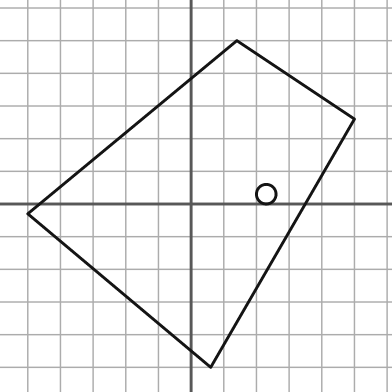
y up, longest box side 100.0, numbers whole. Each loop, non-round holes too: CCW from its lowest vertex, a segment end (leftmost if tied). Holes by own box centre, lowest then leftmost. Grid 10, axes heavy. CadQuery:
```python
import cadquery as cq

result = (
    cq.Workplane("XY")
    .moveTo(6.0, -50.0)
    .lineTo(50.0, 26.0)
    .lineTo(14.0, 50.0)
    .lineTo(-50.0, -3.0)
    .close()
    .moveTo(23.0, 3.0)
    .circle(3.0)
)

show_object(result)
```